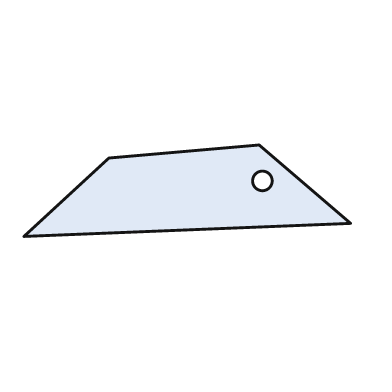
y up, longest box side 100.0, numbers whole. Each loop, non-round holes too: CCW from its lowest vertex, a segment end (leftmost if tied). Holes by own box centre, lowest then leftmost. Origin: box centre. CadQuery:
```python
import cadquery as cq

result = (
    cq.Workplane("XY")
    .moveTo(-50.0, -14.0)
    .lineTo(50.0, -10.0)
    .lineTo(22.0, 14.0)
    .lineTo(-24.0, 10.0)
    .close()
    .moveTo(23.0, 3.0)
    .circle(3.0)
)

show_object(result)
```